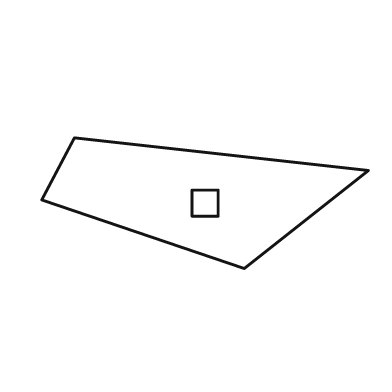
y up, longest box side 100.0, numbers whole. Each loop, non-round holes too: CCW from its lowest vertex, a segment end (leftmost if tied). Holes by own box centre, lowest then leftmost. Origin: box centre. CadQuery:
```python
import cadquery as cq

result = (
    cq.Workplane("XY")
    .moveTo(12.0, -20.0)
    .lineTo(50.0, 10.0)
    .lineTo(-40.0, 20.0)
    .lineTo(-50.0, 1.0)
    .close()
    .moveTo(-4.0, -4.0)
    .lineTo(4.0, -4.0)
    .lineTo(4.0, 4.0)
    .lineTo(-4.0, 4.0)
    .close()
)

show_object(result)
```